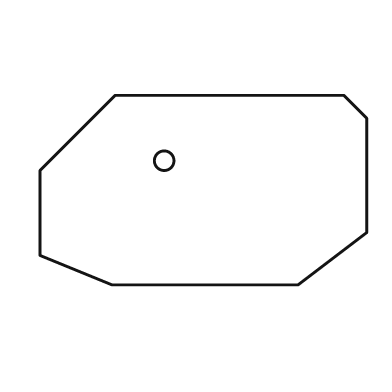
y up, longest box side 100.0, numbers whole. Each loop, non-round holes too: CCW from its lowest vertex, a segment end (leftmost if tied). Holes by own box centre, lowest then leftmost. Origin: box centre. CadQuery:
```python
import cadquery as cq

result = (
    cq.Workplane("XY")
    .moveTo(-28.0, -29.0)
    .lineTo(29.0, -29.0)
    .lineTo(50.0, -13.0)
    .lineTo(50.0, 22.0)
    .lineTo(43.0, 29.0)
    .lineTo(-27.0, 29.0)
    .lineTo(-50.0, 6.0)
    .lineTo(-50.0, -20.0)
    .close()
    .moveTo(-12.0, 9.0)
    .circle(3.0)
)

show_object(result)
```